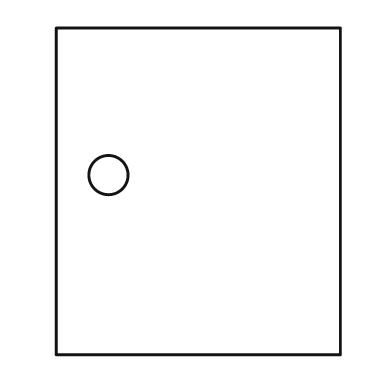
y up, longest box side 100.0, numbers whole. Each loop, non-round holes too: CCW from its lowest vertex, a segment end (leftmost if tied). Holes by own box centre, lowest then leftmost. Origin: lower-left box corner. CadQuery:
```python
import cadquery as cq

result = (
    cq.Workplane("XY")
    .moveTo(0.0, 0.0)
    .lineTo(87.0, 0.0)
    .lineTo(87.0, 100.0)
    .lineTo(0.0, 100.0)
    .close()
    .moveTo(16.0, 55.0)
    .circle(6.0)
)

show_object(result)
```